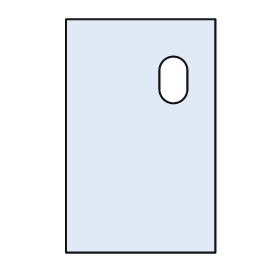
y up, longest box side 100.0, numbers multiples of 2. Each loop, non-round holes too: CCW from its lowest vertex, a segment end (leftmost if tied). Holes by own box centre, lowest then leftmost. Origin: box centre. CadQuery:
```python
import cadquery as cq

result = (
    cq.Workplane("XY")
    .moveTo(-32.0, -50.0)
    .lineTo(32.0, -50.0)
    .lineTo(32.0, 50.0)
    .lineTo(-32.0, 50.0)
    .close()
    .moveTo(8.0, 20.0)
    .threePointArc((14.0, 14.0), (20.0, 20.0))
    .lineTo(20.0, 28.0)
    .threePointArc((14.0, 34.0), (8.0, 28.0))
    .close()
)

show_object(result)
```